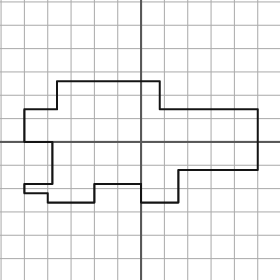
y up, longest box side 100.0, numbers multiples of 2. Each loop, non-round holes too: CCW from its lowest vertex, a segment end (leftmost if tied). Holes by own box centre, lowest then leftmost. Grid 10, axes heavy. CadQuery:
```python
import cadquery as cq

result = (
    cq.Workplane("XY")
    .moveTo(-40.0, -26.0)
    .lineTo(-20.0, -26.0)
    .lineTo(-20.0, -18.0)
    .lineTo(0.0, -18.0)
    .lineTo(0.0, -26.0)
    .lineTo(16.0, -26.0)
    .lineTo(16.0, -12.0)
    .lineTo(50.0, -12.0)
    .lineTo(50.0, 14.0)
    .lineTo(8.0, 14.0)
    .lineTo(8.0, 26.0)
    .lineTo(-36.0, 26.0)
    .lineTo(-36.0, 14.0)
    .lineTo(-50.0, 14.0)
    .lineTo(-50.0, 0.0)
    .lineTo(-38.0, 0.0)
    .lineTo(-38.0, -18.0)
    .lineTo(-50.0, -18.0)
    .lineTo(-50.0, -22.0)
    .lineTo(-40.0, -22.0)
    .close()
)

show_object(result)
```